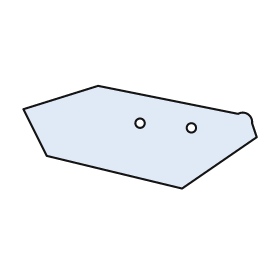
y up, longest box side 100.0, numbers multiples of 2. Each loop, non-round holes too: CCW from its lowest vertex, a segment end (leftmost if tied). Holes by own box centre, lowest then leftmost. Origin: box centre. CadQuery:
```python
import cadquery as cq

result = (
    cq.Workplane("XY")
    .moveTo(18.0, -22.0)
    .lineTo(50.0, 0.0)
    .lineTo(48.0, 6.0)
    .threePointArc((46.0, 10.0), (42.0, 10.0))
    .lineTo(-18.0, 22.0)
    .lineTo(-50.0, 12.0)
    .lineTo(-40.0, -8.0)
    .close()
    .moveTo(22.0, 4.0)
    .circle(2.0)
    .moveTo(0.0, 6.0)
    .circle(2.0)
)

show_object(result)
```